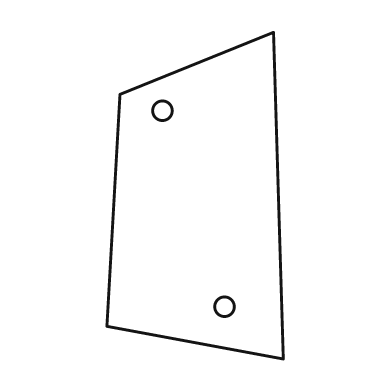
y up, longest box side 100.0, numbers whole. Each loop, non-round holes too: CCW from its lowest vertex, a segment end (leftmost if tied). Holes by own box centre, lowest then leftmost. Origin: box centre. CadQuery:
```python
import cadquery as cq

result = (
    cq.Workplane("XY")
    .moveTo(27.0, -50.0)
    .lineTo(24.0, 50.0)
    .lineTo(-23.0, 31.0)
    .lineTo(-27.0, -40.0)
    .close()
    .moveTo(9.0, -34.0)
    .circle(3.0)
    .moveTo(-10.0, 26.0)
    .circle(3.0)
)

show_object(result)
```